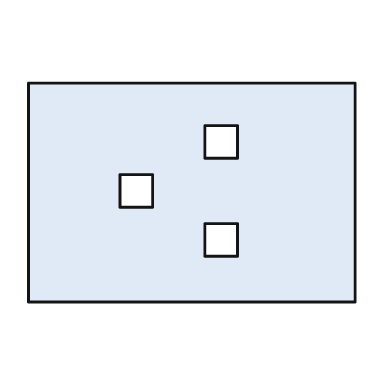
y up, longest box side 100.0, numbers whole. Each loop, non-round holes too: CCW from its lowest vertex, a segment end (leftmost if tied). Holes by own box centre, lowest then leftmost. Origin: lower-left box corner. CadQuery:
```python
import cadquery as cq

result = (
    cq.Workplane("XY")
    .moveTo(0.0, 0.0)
    .lineTo(100.0, 0.0)
    .lineTo(100.0, 67.0)
    .lineTo(0.0, 67.0)
    .close()
    .moveTo(54.0, 14.0)
    .lineTo(64.0, 14.0)
    .lineTo(64.0, 24.0)
    .lineTo(54.0, 24.0)
    .close()
    .moveTo(28.0, 29.0)
    .lineTo(38.0, 29.0)
    .lineTo(38.0, 39.0)
    .lineTo(28.0, 39.0)
    .close()
    .moveTo(54.0, 44.0)
    .lineTo(64.0, 44.0)
    .lineTo(64.0, 54.0)
    .lineTo(54.0, 54.0)
    .close()
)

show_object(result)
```